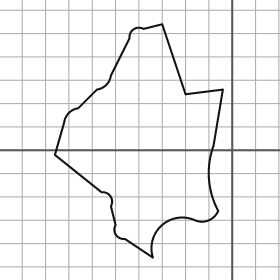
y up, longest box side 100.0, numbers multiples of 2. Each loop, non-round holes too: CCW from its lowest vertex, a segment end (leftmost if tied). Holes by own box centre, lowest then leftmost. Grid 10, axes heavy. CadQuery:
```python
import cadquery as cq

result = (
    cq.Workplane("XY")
    .moveTo(-34.0, -46.0)
    .threePointArc((-30.0, -32.0), (-16.0, -30.0))
    .threePointArc((-10.0, -30.0), (-6.0, -26.0))
    .threePointArc((-10.0, -12.0), (-8.0, 2.0))
    .lineTo(-4.0, 26.0)
    .lineTo(-20.0, 24.0)
    .lineTo(-30.0, 54.0)
    .lineTo(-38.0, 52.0)
    .threePointArc((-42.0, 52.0), (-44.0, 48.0))
    .lineTo(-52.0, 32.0)
    .threePointArc((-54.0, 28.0), (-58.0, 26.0))
    .lineTo(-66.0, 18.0)
    .threePointArc((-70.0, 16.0), (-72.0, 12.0))
    .lineTo(-76.0, -2.0)
    .lineTo(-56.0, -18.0)
    .threePointArc((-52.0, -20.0), (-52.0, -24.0))
    .lineTo(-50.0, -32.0)
    .threePointArc((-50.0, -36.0), (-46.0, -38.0))
    .close()
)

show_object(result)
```